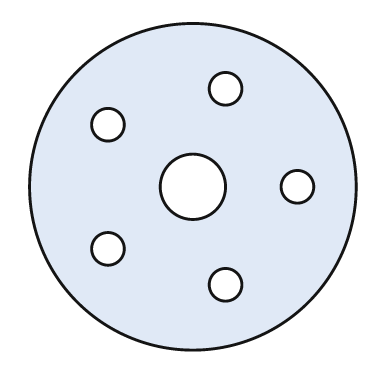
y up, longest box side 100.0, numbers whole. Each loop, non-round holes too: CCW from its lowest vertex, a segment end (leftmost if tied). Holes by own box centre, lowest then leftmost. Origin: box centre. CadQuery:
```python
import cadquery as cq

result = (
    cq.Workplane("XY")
    .moveTo(0.0, 0.0)
    .circle(50.0)
    .moveTo(10.0, -30.0)
    .circle(5.0)
    .moveTo(-26.0, -19.0)
    .circle(5.0)
    .moveTo(0.0, 0.0)
    .circle(10.0)
    .moveTo(32.0, 0.0)
    .circle(5.0)
    .moveTo(-26.0, 19.0)
    .circle(5.0)
    .moveTo(10.0, 30.0)
    .circle(5.0)
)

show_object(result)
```